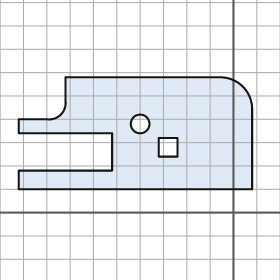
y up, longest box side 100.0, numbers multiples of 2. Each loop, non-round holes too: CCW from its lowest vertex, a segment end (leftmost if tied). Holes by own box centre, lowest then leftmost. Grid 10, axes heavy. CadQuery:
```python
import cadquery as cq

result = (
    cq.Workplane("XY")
    .moveTo(-92.0, 10.0)
    .lineTo(8.0, 10.0)
    .lineTo(8.0, 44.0)
    .threePointArc((4.0, 54.0), (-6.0, 58.0))
    .lineTo(-72.0, 58.0)
    .lineTo(-72.0, 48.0)
    .threePointArc((-74.0, 42.0), (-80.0, 40.0))
    .lineTo(-92.0, 40.0)
    .lineTo(-92.0, 34.0)
    .lineTo(-52.0, 34.0)
    .lineTo(-52.0, 18.0)
    .lineTo(-92.0, 18.0)
    .close()
    .moveTo(-32.0, 24.0)
    .lineTo(-24.0, 24.0)
    .lineTo(-24.0, 32.0)
    .lineTo(-32.0, 32.0)
    .close()
    .moveTo(-40.0, 38.0)
    .circle(4.0)
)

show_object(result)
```